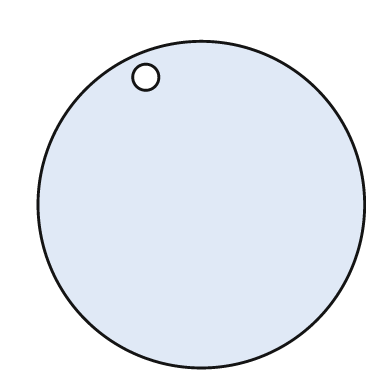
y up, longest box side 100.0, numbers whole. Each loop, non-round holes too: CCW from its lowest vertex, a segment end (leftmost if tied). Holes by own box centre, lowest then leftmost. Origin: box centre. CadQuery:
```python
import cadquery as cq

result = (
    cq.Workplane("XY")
    .moveTo(0.0, 0.0)
    .circle(50.0)
    .moveTo(-17.0, 39.0)
    .circle(4.0)
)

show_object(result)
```